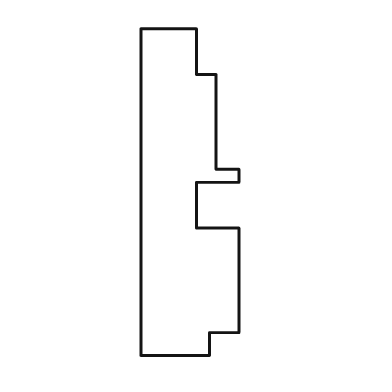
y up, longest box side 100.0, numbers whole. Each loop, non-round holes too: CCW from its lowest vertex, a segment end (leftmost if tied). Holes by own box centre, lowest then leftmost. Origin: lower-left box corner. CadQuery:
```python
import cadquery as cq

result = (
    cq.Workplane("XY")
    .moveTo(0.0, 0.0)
    .lineTo(21.0, 0.0)
    .lineTo(21.0, 7.0)
    .lineTo(30.0, 7.0)
    .lineTo(30.0, 39.0)
    .lineTo(17.0, 39.0)
    .lineTo(17.0, 53.0)
    .lineTo(30.0, 53.0)
    .lineTo(30.0, 57.0)
    .lineTo(23.0, 57.0)
    .lineTo(23.0, 86.0)
    .lineTo(17.0, 86.0)
    .lineTo(17.0, 100.0)
    .lineTo(0.0, 100.0)
    .close()
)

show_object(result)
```